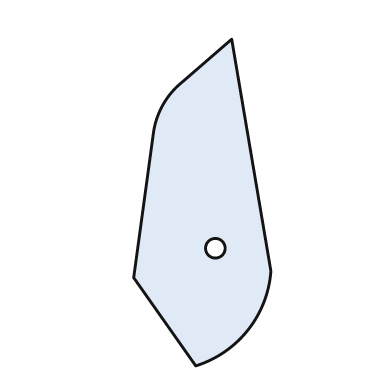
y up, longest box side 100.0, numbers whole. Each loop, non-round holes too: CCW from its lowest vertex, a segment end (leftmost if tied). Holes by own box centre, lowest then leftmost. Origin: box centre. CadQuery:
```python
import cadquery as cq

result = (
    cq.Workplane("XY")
    .moveTo(-2.0, -50.0)
    .threePointArc((14.0, -39.0), (21.0, -21.0))
    .lineTo(9.0, 50.0)
    .lineTo(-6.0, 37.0)
    .threePointArc((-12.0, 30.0), (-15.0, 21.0))
    .lineTo(-21.0, -23.0)
    .close()
    .moveTo(4.0, -14.0)
    .circle(3.0)
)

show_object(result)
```